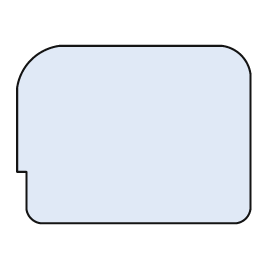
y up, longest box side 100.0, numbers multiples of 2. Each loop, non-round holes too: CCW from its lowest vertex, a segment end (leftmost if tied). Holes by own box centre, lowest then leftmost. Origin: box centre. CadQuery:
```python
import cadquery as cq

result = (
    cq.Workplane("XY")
    .moveTo(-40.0, -38.0)
    .lineTo(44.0, -38.0)
    .threePointArc((48.0, -36.0), (50.0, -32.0))
    .lineTo(50.0, 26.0)
    .threePointArc((46.0, 34.0), (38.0, 38.0))
    .lineTo(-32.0, 38.0)
    .threePointArc((-44.0, 32.0), (-50.0, 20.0))
    .lineTo(-50.0, -16.0)
    .lineTo(-46.0, -16.0)
    .lineTo(-46.0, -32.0)
    .threePointArc((-44.0, -36.0), (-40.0, -38.0))
    .close()
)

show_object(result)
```